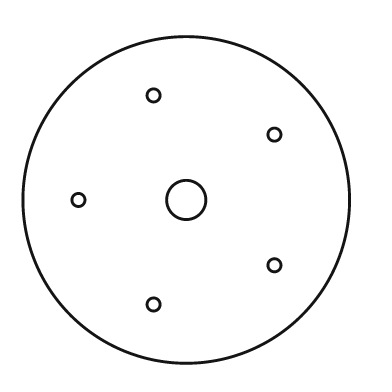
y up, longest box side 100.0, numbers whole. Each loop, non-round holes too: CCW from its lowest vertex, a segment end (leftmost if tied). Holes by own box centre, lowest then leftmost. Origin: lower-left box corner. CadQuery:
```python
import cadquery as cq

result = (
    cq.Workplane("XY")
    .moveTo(50.0, 50.0)
    .circle(50.0)
    .moveTo(40.0, 18.0)
    .circle(2.0)
    .moveTo(77.0, 30.0)
    .circle(2.0)
    .moveTo(17.0, 50.0)
    .circle(2.0)
    .moveTo(50.0, 50.0)
    .circle(6.0)
    .moveTo(77.0, 70.0)
    .circle(2.0)
    .moveTo(40.0, 82.0)
    .circle(2.0)
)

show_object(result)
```